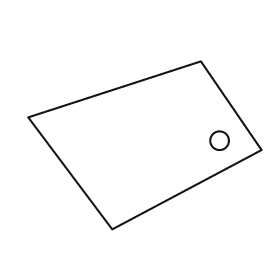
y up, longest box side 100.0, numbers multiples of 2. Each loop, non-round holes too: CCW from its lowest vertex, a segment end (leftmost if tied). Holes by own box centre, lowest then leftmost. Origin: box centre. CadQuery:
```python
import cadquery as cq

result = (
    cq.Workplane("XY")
    .moveTo(-14.0, -36.0)
    .lineTo(50.0, -2.0)
    .lineTo(24.0, 36.0)
    .lineTo(-50.0, 12.0)
    .close()
    .moveTo(32.0, 2.0)
    .circle(4.0)
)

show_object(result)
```